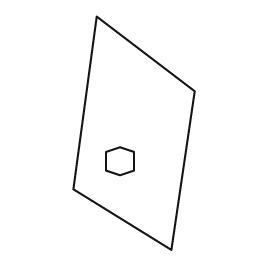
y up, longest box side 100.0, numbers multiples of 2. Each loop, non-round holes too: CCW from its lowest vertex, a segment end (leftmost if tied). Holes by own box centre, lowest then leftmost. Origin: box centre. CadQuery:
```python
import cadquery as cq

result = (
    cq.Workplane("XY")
    .moveTo(16.0, -50.0)
    .lineTo(26.0, 18.0)
    .lineTo(-16.0, 50.0)
    .lineTo(-26.0, -24.0)
    .close()
    .moveTo(-6.0, -18.0)
    .lineTo(0.0, -16.0)
    .lineTo(0.0, -8.0)
    .lineTo(-6.0, -6.0)
    .lineTo(-12.0, -8.0)
    .lineTo(-12.0, -16.0)
    .close()
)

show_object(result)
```